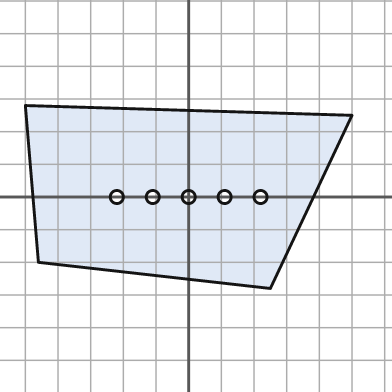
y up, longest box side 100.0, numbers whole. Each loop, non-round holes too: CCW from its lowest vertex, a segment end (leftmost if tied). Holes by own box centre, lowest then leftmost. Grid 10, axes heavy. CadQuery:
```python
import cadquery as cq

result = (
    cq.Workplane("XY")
    .moveTo(25.0, -28.0)
    .lineTo(50.0, 25.0)
    .lineTo(-50.0, 28.0)
    .lineTo(-46.0, -20.0)
    .close()
    .moveTo(-22.0, 0.0)
    .circle(2.0)
    .moveTo(-11.0, 0.0)
    .circle(2.0)
    .moveTo(0.0, 0.0)
    .circle(2.0)
    .moveTo(11.0, 0.0)
    .circle(2.0)
    .moveTo(22.0, 0.0)
    .circle(2.0)
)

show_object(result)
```